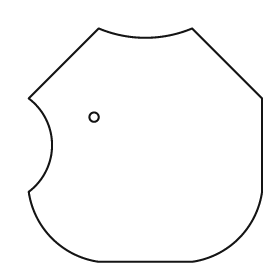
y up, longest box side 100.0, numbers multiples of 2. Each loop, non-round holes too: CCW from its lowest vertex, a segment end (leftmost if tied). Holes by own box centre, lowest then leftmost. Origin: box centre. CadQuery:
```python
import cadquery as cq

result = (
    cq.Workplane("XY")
    .moveTo(-20.0, -50.0)
    .lineTo(20.0, -50.0)
    .threePointArc((40.0, -40.0), (50.0, -20.0))
    .lineTo(50.0, 20.0)
    .lineTo(20.0, 50.0)
    .threePointArc((0.0, 46.0), (-20.0, 50.0))
    .lineTo(-50.0, 20.0)
    .threePointArc((-40.0, 0.0), (-50.0, -20.0))
    .threePointArc((-40.0, -40.0), (-20.0, -50.0))
    .close()
    .moveTo(-22.0, 12.0)
    .circle(2.0)
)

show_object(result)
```